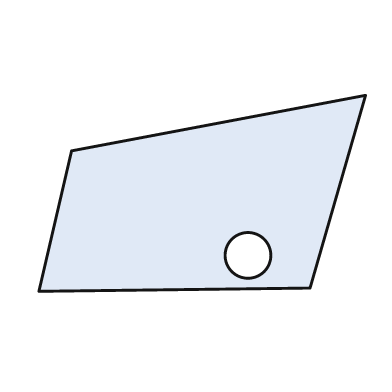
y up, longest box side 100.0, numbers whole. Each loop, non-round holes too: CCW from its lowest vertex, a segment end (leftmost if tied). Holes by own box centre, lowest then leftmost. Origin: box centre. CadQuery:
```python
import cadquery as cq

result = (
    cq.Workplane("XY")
    .moveTo(-50.0, -30.0)
    .lineTo(33.0, -29.0)
    .lineTo(50.0, 30.0)
    .lineTo(-40.0, 13.0)
    .close()
    .moveTo(14.0, -19.0)
    .circle(7.0)
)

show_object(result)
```